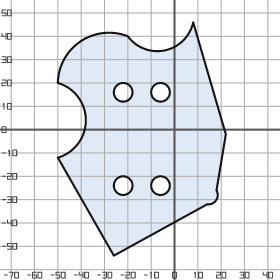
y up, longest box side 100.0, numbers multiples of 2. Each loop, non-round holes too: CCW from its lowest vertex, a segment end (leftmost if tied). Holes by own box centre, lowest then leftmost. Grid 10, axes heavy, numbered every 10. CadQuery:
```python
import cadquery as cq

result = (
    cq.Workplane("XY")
    .moveTo(-26.0, -54.0)
    .lineTo(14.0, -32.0)
    .threePointArc((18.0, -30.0), (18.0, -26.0))
    .lineTo(22.0, -2.0)
    .lineTo(8.0, 46.0)
    .threePointArc((-4.0, 34.0), (-20.0, 40.0))
    .threePointArc((-40.0, 38.0), (-50.0, 20.0))
    .threePointArc((-38.0, 4.0), (-50.0, -12.0))
    .close()
    .moveTo(-22.0, -24.0)
    .circle(4.0)
    .moveTo(-6.0, -24.0)
    .circle(4.0)
    .moveTo(-22.0, 16.0)
    .circle(4.0)
    .moveTo(-6.0, 16.0)
    .circle(4.0)
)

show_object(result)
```